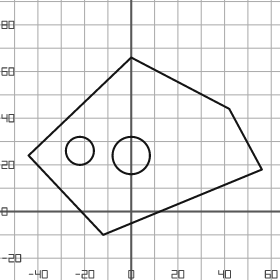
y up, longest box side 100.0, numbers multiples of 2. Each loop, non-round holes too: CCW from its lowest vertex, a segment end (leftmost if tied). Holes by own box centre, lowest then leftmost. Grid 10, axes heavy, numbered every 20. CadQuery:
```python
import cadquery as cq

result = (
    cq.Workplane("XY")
    .moveTo(-12.0, -10.0)
    .lineTo(56.0, 18.0)
    .lineTo(42.0, 44.0)
    .lineTo(0.0, 66.0)
    .lineTo(-44.0, 24.0)
    .close()
    .moveTo(0.0, 24.0)
    .circle(8.0)
    .moveTo(-22.0, 26.0)
    .circle(6.0)
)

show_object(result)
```